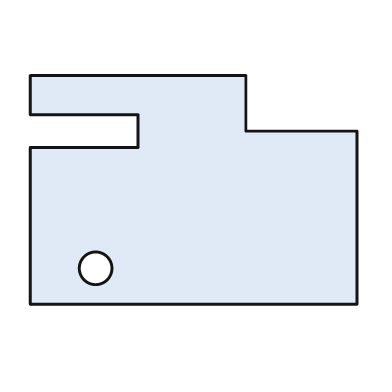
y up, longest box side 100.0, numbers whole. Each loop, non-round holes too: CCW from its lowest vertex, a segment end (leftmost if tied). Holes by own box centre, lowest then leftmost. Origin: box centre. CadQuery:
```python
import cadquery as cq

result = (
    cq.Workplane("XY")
    .moveTo(-50.0, -35.0)
    .lineTo(50.0, -35.0)
    .lineTo(50.0, 18.0)
    .lineTo(16.0, 18.0)
    .lineTo(16.0, 35.0)
    .lineTo(-50.0, 35.0)
    .lineTo(-50.0, 23.0)
    .lineTo(-17.0, 23.0)
    .lineTo(-17.0, 13.0)
    .lineTo(-50.0, 13.0)
    .close()
    .moveTo(-30.0, -24.0)
    .circle(5.0)
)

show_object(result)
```